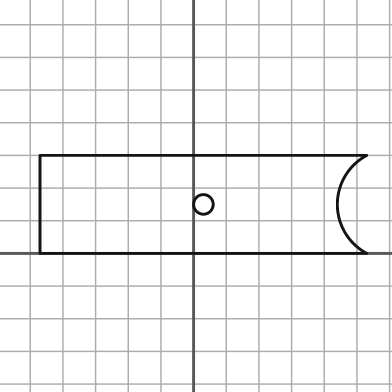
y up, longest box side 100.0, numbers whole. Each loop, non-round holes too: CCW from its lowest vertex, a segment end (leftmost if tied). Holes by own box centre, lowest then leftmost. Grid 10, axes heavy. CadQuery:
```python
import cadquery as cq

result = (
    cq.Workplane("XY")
    .moveTo(-47.0, 0.0)
    .lineTo(53.0, 0.0)
    .threePointArc((44.0, 15.0), (53.0, 30.0))
    .lineTo(-47.0, 30.0)
    .close()
    .moveTo(3.0, 15.0)
    .circle(3.0)
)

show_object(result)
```